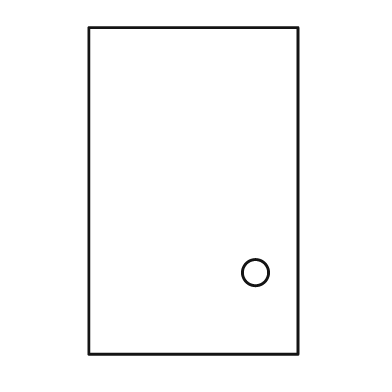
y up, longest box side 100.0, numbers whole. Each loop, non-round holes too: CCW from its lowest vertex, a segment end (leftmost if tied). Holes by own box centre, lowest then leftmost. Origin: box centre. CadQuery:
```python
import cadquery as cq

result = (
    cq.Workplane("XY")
    .moveTo(-32.0, -50.0)
    .lineTo(32.0, -50.0)
    .lineTo(32.0, 50.0)
    .lineTo(-32.0, 50.0)
    .close()
    .moveTo(19.0, -25.0)
    .circle(4.0)
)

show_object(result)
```